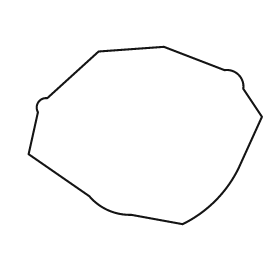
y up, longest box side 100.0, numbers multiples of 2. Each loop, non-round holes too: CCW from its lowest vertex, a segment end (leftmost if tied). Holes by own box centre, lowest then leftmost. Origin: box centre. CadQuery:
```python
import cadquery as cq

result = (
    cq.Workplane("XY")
    .moveTo(16.0, -38.0)
    .threePointArc((30.0, -28.0), (40.0, -14.0))
    .lineTo(50.0, 8.0)
    .lineTo(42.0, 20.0)
    .threePointArc((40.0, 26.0), (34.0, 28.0))
    .lineTo(8.0, 38.0)
    .lineTo(-20.0, 36.0)
    .lineTo(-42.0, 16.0)
    .threePointArc((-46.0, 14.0), (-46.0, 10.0))
    .lineTo(-50.0, -8.0)
    .lineTo(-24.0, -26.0)
    .threePointArc((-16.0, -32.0), (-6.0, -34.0))
    .close()
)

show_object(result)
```